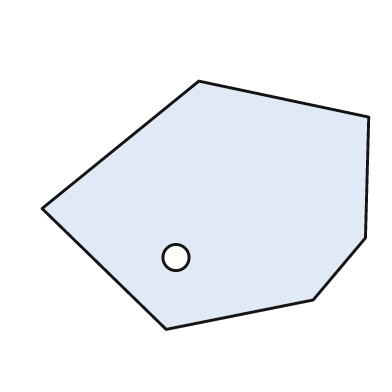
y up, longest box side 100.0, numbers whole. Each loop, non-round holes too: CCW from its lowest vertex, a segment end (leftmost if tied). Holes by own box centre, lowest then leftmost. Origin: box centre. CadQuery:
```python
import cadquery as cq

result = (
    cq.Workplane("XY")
    .moveTo(-12.0, -38.0)
    .lineTo(33.0, -29.0)
    .lineTo(49.0, -10.0)
    .lineTo(50.0, 27.0)
    .lineTo(-2.0, 38.0)
    .lineTo(-50.0, -1.0)
    .close()
    .moveTo(-9.0, -16.0)
    .circle(4.0)
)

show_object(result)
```